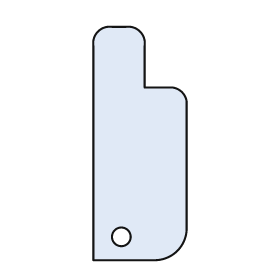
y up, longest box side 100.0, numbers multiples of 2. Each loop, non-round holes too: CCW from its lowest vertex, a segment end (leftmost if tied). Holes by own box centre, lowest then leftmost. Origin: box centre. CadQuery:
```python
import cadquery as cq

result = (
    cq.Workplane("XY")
    .moveTo(-20.0, -50.0)
    .lineTo(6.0, -50.0)
    .threePointArc((16.0, -46.0), (20.0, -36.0))
    .lineTo(20.0, 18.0)
    .threePointArc((18.0, 22.0), (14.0, 24.0))
    .lineTo(2.0, 24.0)
    .lineTo(2.0, 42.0)
    .threePointArc((0.0, 48.0), (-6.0, 50.0))
    .lineTo(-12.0, 50.0)
    .threePointArc((-18.0, 48.0), (-20.0, 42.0))
    .close()
    .moveTo(-8.0, -40.0)
    .circle(4.0)
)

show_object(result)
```